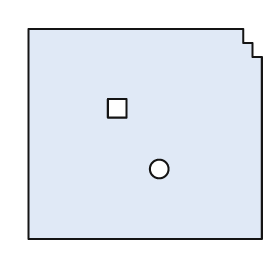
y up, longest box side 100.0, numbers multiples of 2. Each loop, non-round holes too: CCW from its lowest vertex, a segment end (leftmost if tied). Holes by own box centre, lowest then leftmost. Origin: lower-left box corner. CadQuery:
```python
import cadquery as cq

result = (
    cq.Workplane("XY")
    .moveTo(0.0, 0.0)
    .lineTo(100.0, 0.0)
    .lineTo(100.0, 78.0)
    .lineTo(96.0, 78.0)
    .lineTo(96.0, 84.0)
    .lineTo(92.0, 84.0)
    .lineTo(92.0, 90.0)
    .lineTo(0.0, 90.0)
    .close()
    .moveTo(56.0, 30.0)
    .circle(4.0)
    .moveTo(34.0, 52.0)
    .lineTo(42.0, 52.0)
    .lineTo(42.0, 60.0)
    .lineTo(34.0, 60.0)
    .close()
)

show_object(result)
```